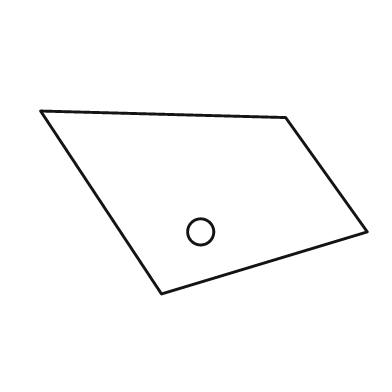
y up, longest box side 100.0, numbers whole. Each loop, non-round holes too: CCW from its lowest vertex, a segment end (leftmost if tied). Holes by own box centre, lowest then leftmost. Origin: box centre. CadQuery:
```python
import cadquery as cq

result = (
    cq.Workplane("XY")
    .moveTo(-13.0, -28.0)
    .lineTo(50.0, -9.0)
    .lineTo(25.0, 26.0)
    .lineTo(-50.0, 28.0)
    .close()
    .moveTo(-1.0, -9.0)
    .circle(4.0)
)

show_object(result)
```